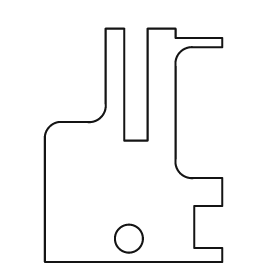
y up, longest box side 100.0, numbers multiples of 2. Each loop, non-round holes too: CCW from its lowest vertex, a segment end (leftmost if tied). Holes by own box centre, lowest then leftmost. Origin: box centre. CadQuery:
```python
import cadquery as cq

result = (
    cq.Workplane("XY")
    .moveTo(-38.0, -50.0)
    .lineTo(38.0, -50.0)
    .lineTo(38.0, -44.0)
    .lineTo(26.0, -44.0)
    .lineTo(26.0, -26.0)
    .lineTo(38.0, -26.0)
    .lineTo(38.0, -14.0)
    .lineTo(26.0, -14.0)
    .threePointArc((20.0, -12.0), (18.0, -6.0))
    .lineTo(18.0, 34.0)
    .threePointArc((20.0, 40.0), (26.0, 42.0))
    .lineTo(38.0, 42.0)
    .lineTo(38.0, 46.0)
    .lineTo(18.0, 46.0)
    .lineTo(18.0, 50.0)
    .lineTo(6.0, 50.0)
    .lineTo(6.0, 2.0)
    .lineTo(-4.0, 2.0)
    .lineTo(-4.0, 50.0)
    .lineTo(-12.0, 50.0)
    .lineTo(-12.0, 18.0)
    .threePointArc((-14.0, 12.0), (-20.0, 10.0))
    .lineTo(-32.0, 10.0)
    .threePointArc((-36.0, 8.0), (-38.0, 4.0))
    .close()
    .moveTo(-2.0, -40.0)
    .circle(6.0)
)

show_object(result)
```